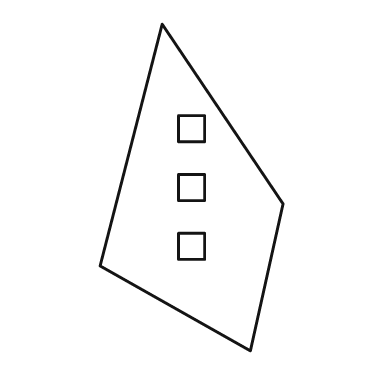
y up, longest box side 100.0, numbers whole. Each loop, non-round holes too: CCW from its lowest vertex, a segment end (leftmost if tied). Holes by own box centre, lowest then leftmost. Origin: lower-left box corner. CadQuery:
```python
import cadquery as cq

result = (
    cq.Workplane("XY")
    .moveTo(46.0, 0.0)
    .lineTo(56.0, 45.0)
    .lineTo(19.0, 100.0)
    .lineTo(0.0, 26.0)
    .close()
    .moveTo(24.0, 28.0)
    .lineTo(32.0, 28.0)
    .lineTo(32.0, 36.0)
    .lineTo(24.0, 36.0)
    .close()
    .moveTo(24.0, 46.0)
    .lineTo(32.0, 46.0)
    .lineTo(32.0, 54.0)
    .lineTo(24.0, 54.0)
    .close()
    .moveTo(24.0, 64.0)
    .lineTo(32.0, 64.0)
    .lineTo(32.0, 72.0)
    .lineTo(24.0, 72.0)
    .close()
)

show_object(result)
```